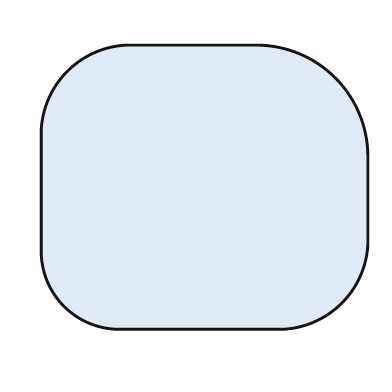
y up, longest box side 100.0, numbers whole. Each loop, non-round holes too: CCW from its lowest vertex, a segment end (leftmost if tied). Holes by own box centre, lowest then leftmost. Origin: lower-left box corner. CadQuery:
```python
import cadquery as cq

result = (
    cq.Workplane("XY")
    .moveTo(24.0, 0.0)
    .lineTo(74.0, 0.0)
    .threePointArc((92.0, 8.0), (100.0, 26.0))
    .lineTo(100.0, 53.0)
    .threePointArc((90.0, 77.0), (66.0, 87.0))
    .lineTo(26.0, 87.0)
    .threePointArc((8.0, 79.0), (0.0, 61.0))
    .lineTo(0.0, 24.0)
    .threePointArc((7.0, 7.0), (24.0, 0.0))
    .close()
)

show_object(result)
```